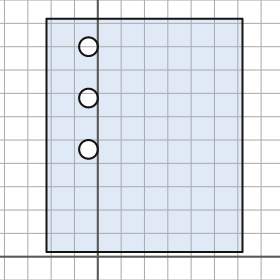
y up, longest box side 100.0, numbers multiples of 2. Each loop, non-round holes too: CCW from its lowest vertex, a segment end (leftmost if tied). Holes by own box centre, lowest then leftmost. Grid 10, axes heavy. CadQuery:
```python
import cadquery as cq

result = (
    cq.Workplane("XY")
    .moveTo(-22.0, 2.0)
    .lineTo(62.0, 2.0)
    .lineTo(62.0, 102.0)
    .lineTo(-22.0, 102.0)
    .close()
    .moveTo(-4.0, 46.0)
    .circle(4.0)
    .moveTo(-4.0, 68.0)
    .circle(4.0)
    .moveTo(-4.0, 90.0)
    .circle(4.0)
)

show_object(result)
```